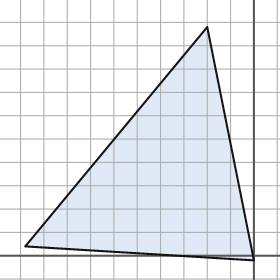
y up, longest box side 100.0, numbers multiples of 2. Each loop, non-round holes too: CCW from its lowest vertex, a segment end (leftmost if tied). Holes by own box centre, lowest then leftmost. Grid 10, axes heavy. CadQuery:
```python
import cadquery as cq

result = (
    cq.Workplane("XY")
    .moveTo(0.0, -2.0)
    .lineTo(-20.0, 98.0)
    .lineTo(-98.0, 4.0)
    .close()
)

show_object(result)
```